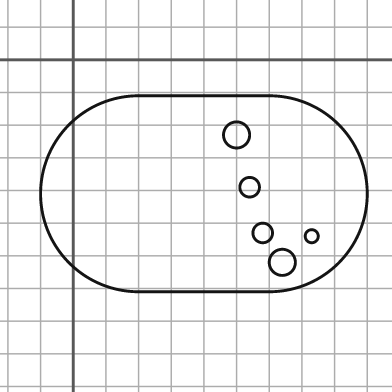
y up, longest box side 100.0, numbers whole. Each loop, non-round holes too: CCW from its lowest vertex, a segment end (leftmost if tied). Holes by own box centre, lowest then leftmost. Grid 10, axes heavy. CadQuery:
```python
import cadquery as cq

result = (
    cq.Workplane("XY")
    .moveTo(20.0, -71.0)
    .lineTo(60.0, -71.0)
    .threePointArc((90.0, -41.0), (60.0, -11.0))
    .lineTo(20.0, -11.0)
    .threePointArc((-10.0, -41.0), (20.0, -71.0))
    .close()
    .moveTo(64.0, -62.0)
    .circle(4.0)
    .moveTo(73.0, -54.0)
    .circle(2.0)
    .moveTo(58.0, -53.0)
    .circle(3.0)
    .moveTo(54.0, -39.0)
    .circle(3.0)
    .moveTo(50.0, -23.0)
    .circle(4.0)
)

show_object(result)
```